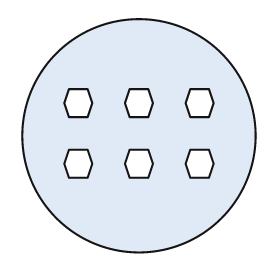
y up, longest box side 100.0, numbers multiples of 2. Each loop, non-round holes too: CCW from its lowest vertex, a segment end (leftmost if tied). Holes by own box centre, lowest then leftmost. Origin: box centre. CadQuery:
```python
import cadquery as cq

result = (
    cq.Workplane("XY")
    .moveTo(0.0, 0.0)
    .circle(50.0)
    .moveTo(-30.0, -18.0)
    .lineTo(-22.0, -18.0)
    .lineTo(-20.0, -12.0)
    .lineTo(-22.0, -6.0)
    .lineTo(-30.0, -6.0)
    .lineTo(-32.0, -12.0)
    .close()
    .moveTo(-4.0, -18.0)
    .lineTo(4.0, -18.0)
    .lineTo(6.0, -12.0)
    .lineTo(4.0, -6.0)
    .lineTo(-4.0, -6.0)
    .lineTo(-6.0, -12.0)
    .close()
    .moveTo(22.0, -18.0)
    .lineTo(30.0, -18.0)
    .lineTo(32.0, -12.0)
    .lineTo(30.0, -6.0)
    .lineTo(22.0, -6.0)
    .lineTo(20.0, -12.0)
    .close()
    .moveTo(-30.0, 8.0)
    .lineTo(-22.0, 8.0)
    .lineTo(-20.0, 14.0)
    .lineTo(-22.0, 20.0)
    .lineTo(-30.0, 20.0)
    .lineTo(-32.0, 14.0)
    .close()
    .moveTo(-4.0, 8.0)
    .lineTo(4.0, 8.0)
    .lineTo(6.0, 14.0)
    .lineTo(4.0, 20.0)
    .lineTo(-4.0, 20.0)
    .lineTo(-6.0, 14.0)
    .close()
    .moveTo(22.0, 8.0)
    .lineTo(30.0, 8.0)
    .lineTo(32.0, 14.0)
    .lineTo(30.0, 20.0)
    .lineTo(22.0, 20.0)
    .lineTo(20.0, 14.0)
    .close()
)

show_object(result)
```